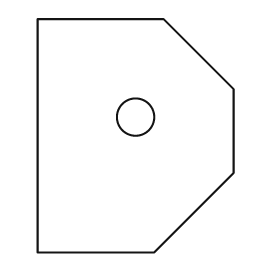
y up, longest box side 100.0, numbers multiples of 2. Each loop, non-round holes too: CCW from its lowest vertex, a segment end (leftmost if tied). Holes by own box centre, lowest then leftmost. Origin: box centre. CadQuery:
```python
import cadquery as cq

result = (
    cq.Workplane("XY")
    .moveTo(-42.0, -50.0)
    .lineTo(8.0, -50.0)
    .lineTo(42.0, -16.0)
    .lineTo(42.0, 20.0)
    .lineTo(12.0, 50.0)
    .lineTo(-42.0, 50.0)
    .close()
    .moveTo(0.0, 8.0)
    .circle(8.0)
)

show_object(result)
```